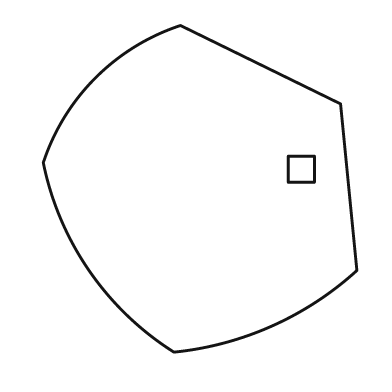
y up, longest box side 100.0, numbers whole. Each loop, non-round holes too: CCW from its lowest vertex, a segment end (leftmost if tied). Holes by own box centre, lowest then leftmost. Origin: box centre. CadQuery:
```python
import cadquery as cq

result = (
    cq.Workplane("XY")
    .moveTo(-8.0, -50.0)
    .threePointArc((22.0, -42.0), (48.0, -25.0))
    .lineTo(43.0, 26.0)
    .lineTo(-6.0, 50.0)
    .threePointArc((-32.0, 34.0), (-48.0, 8.0))
    .threePointArc((-34.0, -25.0), (-8.0, -50.0))
    .close()
    .moveTo(27.0, 2.0)
    .lineTo(35.0, 2.0)
    .lineTo(35.0, 10.0)
    .lineTo(27.0, 10.0)
    .close()
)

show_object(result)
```